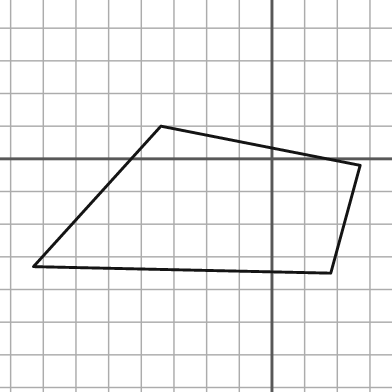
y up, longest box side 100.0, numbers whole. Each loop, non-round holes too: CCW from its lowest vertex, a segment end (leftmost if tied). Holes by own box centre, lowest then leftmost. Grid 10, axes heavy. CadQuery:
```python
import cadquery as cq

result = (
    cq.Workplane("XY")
    .moveTo(18.0, -35.0)
    .lineTo(27.0, -2.0)
    .lineTo(-34.0, 10.0)
    .lineTo(-73.0, -33.0)
    .close()
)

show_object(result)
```